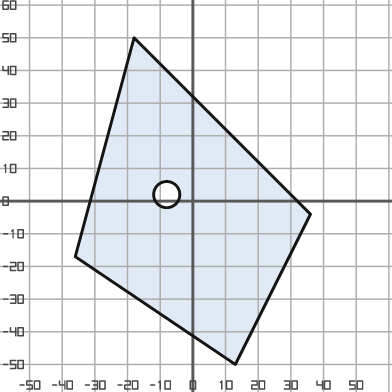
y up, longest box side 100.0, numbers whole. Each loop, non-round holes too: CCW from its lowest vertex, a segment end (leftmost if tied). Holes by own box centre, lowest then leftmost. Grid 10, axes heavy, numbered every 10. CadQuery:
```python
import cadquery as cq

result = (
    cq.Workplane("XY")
    .moveTo(13.0, -50.0)
    .lineTo(36.0, -4.0)
    .lineTo(-18.0, 50.0)
    .lineTo(-36.0, -17.0)
    .close()
    .moveTo(-8.0, 2.0)
    .circle(4.0)
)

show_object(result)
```